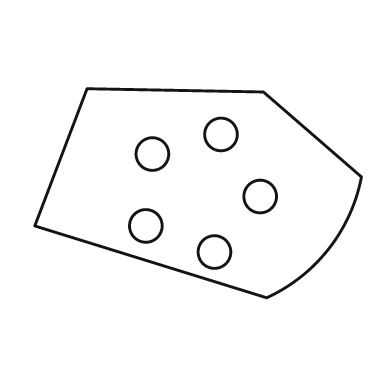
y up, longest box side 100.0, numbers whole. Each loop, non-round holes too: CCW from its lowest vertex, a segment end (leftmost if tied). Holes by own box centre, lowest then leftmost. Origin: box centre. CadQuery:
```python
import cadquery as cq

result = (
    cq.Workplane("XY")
    .moveTo(21.0, -32.0)
    .threePointArc((40.0, -17.0), (50.0, 5.0))
    .lineTo(20.0, 31.0)
    .lineTo(-34.0, 32.0)
    .lineTo(-50.0, -10.0)
    .close()
    .moveTo(5.0, -18.0)
    .circle(5.0)
    .moveTo(-16.0, -10.0)
    .circle(5.0)
    .moveTo(19.0, -1.0)
    .circle(5.0)
    .moveTo(-14.0, 12.0)
    .circle(5.0)
    .moveTo(7.0, 18.0)
    .circle(5.0)
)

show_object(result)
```